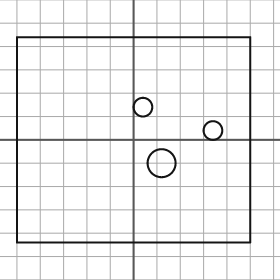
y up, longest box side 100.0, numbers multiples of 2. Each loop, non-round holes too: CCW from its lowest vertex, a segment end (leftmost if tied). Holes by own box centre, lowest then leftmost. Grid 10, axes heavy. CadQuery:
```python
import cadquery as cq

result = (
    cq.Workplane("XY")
    .moveTo(-50.0, -44.0)
    .lineTo(50.0, -44.0)
    .lineTo(50.0, 44.0)
    .lineTo(-50.0, 44.0)
    .close()
    .moveTo(12.0, -10.0)
    .circle(6.0)
    .moveTo(34.0, 4.0)
    .circle(4.0)
    .moveTo(4.0, 14.0)
    .circle(4.0)
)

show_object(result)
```